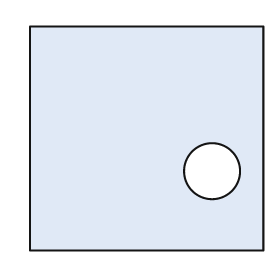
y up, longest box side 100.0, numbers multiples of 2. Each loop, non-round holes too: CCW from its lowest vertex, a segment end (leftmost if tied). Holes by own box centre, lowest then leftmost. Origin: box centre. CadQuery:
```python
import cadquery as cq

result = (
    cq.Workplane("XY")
    .moveTo(-50.0, -48.0)
    .lineTo(50.0, -48.0)
    .lineTo(50.0, 48.0)
    .lineTo(-50.0, 48.0)
    .close()
    .moveTo(28.0, -14.0)
    .circle(12.0)
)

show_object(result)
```